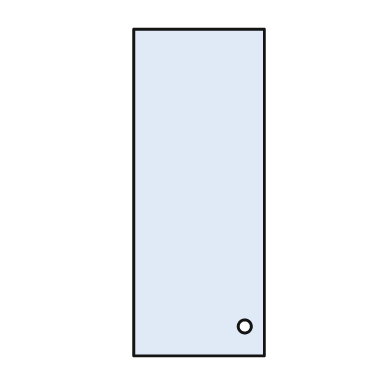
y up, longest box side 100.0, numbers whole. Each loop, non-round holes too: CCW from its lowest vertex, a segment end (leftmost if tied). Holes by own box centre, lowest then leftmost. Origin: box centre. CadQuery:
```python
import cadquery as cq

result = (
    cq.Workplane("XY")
    .moveTo(-20.0, -50.0)
    .lineTo(20.0, -50.0)
    .lineTo(20.0, 50.0)
    .lineTo(-20.0, 50.0)
    .close()
    .moveTo(14.0, -41.0)
    .circle(2.0)
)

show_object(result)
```